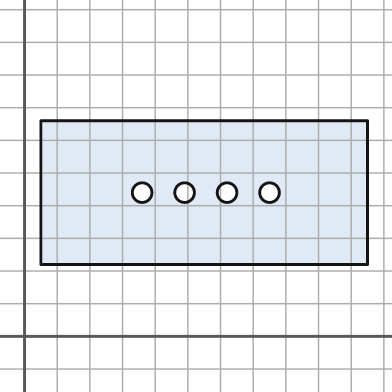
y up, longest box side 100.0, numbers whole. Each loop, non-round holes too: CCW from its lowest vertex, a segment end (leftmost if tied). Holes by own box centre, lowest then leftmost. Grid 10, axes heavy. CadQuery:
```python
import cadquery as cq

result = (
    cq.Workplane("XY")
    .moveTo(5.0, 22.0)
    .lineTo(105.0, 22.0)
    .lineTo(105.0, 66.0)
    .lineTo(5.0, 66.0)
    .close()
    .moveTo(36.0, 44.0)
    .circle(3.0)
    .moveTo(49.0, 44.0)
    .circle(3.0)
    .moveTo(62.0, 44.0)
    .circle(3.0)
    .moveTo(75.0, 44.0)
    .circle(3.0)
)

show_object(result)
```